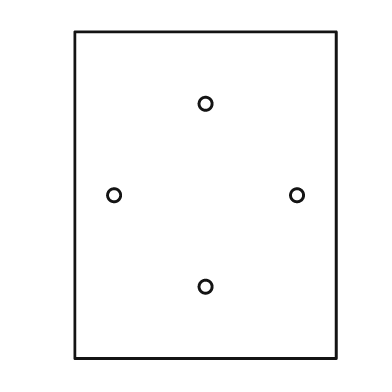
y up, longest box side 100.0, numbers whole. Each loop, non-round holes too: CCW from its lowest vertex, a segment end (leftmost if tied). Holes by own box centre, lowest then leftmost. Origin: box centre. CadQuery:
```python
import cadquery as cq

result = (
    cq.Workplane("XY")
    .moveTo(-40.0, -50.0)
    .lineTo(40.0, -50.0)
    .lineTo(40.0, 50.0)
    .lineTo(-40.0, 50.0)
    .close()
    .moveTo(0.0, -28.0)
    .circle(2.0)
    .moveTo(-28.0, 0.0)
    .circle(2.0)
    .moveTo(28.0, 0.0)
    .circle(2.0)
    .moveTo(0.0, 28.0)
    .circle(2.0)
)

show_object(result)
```